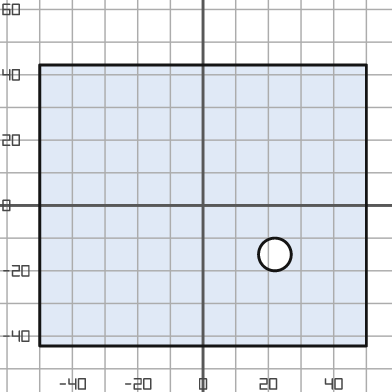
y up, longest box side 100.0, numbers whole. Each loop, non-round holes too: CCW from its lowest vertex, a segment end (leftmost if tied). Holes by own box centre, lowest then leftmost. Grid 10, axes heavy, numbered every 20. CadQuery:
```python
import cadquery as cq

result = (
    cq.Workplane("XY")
    .moveTo(-50.0, -43.0)
    .lineTo(50.0, -43.0)
    .lineTo(50.0, 43.0)
    .lineTo(-50.0, 43.0)
    .close()
    .moveTo(22.0, -15.0)
    .circle(5.0)
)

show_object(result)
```